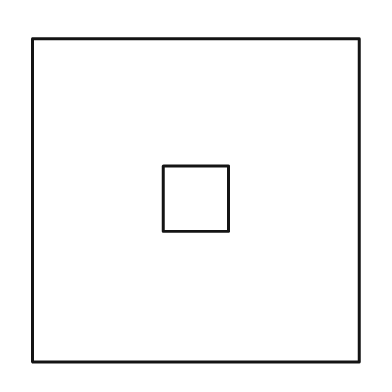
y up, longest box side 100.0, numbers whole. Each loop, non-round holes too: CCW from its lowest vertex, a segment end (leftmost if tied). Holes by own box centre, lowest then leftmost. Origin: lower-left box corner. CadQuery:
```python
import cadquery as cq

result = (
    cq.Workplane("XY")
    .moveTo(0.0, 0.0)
    .lineTo(100.0, 0.0)
    .lineTo(100.0, 99.0)
    .lineTo(0.0, 99.0)
    .close()
    .moveTo(40.0, 40.0)
    .lineTo(60.0, 40.0)
    .lineTo(60.0, 60.0)
    .lineTo(40.0, 60.0)
    .close()
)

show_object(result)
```